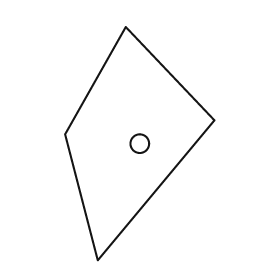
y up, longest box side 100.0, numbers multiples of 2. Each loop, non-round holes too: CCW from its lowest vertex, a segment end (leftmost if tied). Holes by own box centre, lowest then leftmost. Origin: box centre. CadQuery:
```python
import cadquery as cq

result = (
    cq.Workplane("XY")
    .moveTo(-18.0, -50.0)
    .lineTo(32.0, 10.0)
    .lineTo(-6.0, 50.0)
    .lineTo(-32.0, 4.0)
    .close()
    .moveTo(0.0, 0.0)
    .circle(4.0)
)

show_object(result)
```